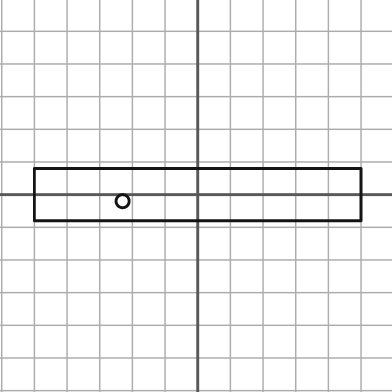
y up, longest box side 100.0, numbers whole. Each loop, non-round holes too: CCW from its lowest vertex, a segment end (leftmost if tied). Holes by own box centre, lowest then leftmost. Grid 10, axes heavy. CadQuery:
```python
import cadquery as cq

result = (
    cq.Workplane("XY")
    .moveTo(-50.0, -8.0)
    .lineTo(50.0, -8.0)
    .lineTo(50.0, 8.0)
    .lineTo(-50.0, 8.0)
    .close()
    .moveTo(-23.0, -2.0)
    .circle(2.0)
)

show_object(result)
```